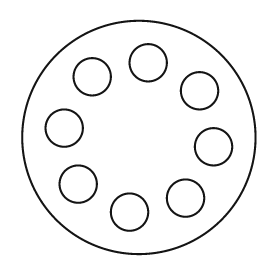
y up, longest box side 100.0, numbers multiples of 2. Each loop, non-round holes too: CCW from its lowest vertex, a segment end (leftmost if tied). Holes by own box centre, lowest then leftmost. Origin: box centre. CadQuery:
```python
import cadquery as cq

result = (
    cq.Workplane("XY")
    .moveTo(0.0, 0.0)
    .circle(50.0)
    .moveTo(-4.0, -32.0)
    .circle(8.0)
    .moveTo(20.0, -26.0)
    .circle(8.0)
    .moveTo(-26.0, -20.0)
    .circle(8.0)
    .moveTo(32.0, -4.0)
    .circle(8.0)
    .moveTo(-32.0, 4.0)
    .circle(8.0)
    .moveTo(26.0, 20.0)
    .circle(8.0)
    .moveTo(-20.0, 26.0)
    .circle(8.0)
    .moveTo(4.0, 32.0)
    .circle(8.0)
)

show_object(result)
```